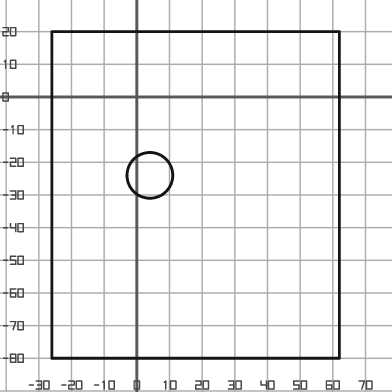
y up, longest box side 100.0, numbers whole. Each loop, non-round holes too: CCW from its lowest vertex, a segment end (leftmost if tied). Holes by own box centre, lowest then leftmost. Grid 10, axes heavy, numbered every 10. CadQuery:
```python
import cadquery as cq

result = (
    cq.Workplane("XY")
    .moveTo(-26.0, -80.0)
    .lineTo(62.0, -80.0)
    .lineTo(62.0, 20.0)
    .lineTo(-26.0, 20.0)
    .close()
    .moveTo(4.0, -24.0)
    .circle(7.0)
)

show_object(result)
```